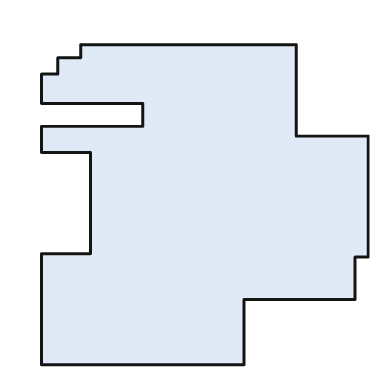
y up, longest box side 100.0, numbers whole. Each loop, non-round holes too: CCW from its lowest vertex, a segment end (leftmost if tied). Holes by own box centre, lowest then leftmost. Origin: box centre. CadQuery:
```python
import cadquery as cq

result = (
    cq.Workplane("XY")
    .moveTo(-50.0, -49.0)
    .lineTo(12.0, -49.0)
    .lineTo(12.0, -29.0)
    .lineTo(46.0, -29.0)
    .lineTo(46.0, -16.0)
    .lineTo(50.0, -16.0)
    .lineTo(50.0, 21.0)
    .lineTo(28.0, 21.0)
    .lineTo(28.0, 49.0)
    .lineTo(-38.0, 49.0)
    .lineTo(-38.0, 45.0)
    .lineTo(-45.0, 45.0)
    .lineTo(-45.0, 40.0)
    .lineTo(-50.0, 40.0)
    .lineTo(-50.0, 31.0)
    .lineTo(-19.0, 31.0)
    .lineTo(-19.0, 24.0)
    .lineTo(-50.0, 24.0)
    .lineTo(-50.0, 16.0)
    .lineTo(-35.0, 16.0)
    .lineTo(-35.0, -15.0)
    .lineTo(-50.0, -15.0)
    .close()
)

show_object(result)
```